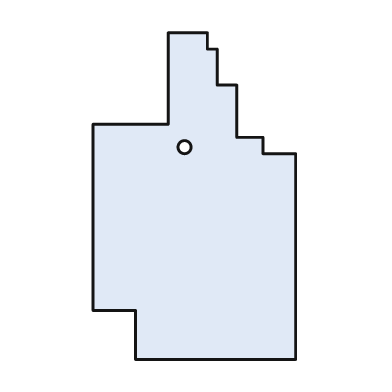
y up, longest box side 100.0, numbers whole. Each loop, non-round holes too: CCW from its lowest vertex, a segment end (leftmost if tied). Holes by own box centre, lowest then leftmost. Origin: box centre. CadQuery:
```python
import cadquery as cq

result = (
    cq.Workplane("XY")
    .moveTo(-18.0, -50.0)
    .lineTo(31.0, -50.0)
    .lineTo(31.0, 13.0)
    .lineTo(21.0, 13.0)
    .lineTo(21.0, 18.0)
    .lineTo(13.0, 18.0)
    .lineTo(13.0, 34.0)
    .lineTo(7.0, 34.0)
    .lineTo(7.0, 45.0)
    .lineTo(4.0, 45.0)
    .lineTo(4.0, 50.0)
    .lineTo(-8.0, 50.0)
    .lineTo(-8.0, 22.0)
    .lineTo(-31.0, 22.0)
    .lineTo(-31.0, -35.0)
    .lineTo(-18.0, -35.0)
    .close()
    .moveTo(-3.0, 15.0)
    .circle(2.0)
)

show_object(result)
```